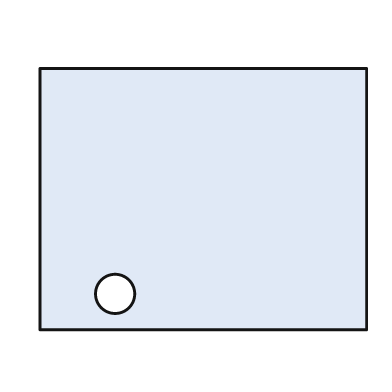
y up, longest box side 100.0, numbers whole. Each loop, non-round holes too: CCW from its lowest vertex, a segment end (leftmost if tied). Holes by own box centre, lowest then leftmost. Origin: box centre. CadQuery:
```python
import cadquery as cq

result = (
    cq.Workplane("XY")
    .moveTo(-50.0, -40.0)
    .lineTo(50.0, -40.0)
    .lineTo(50.0, 40.0)
    .lineTo(-50.0, 40.0)
    .close()
    .moveTo(-27.0, -29.0)
    .circle(6.0)
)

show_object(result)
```